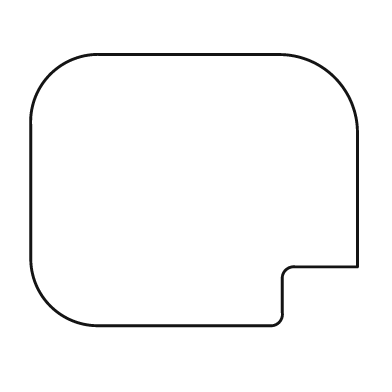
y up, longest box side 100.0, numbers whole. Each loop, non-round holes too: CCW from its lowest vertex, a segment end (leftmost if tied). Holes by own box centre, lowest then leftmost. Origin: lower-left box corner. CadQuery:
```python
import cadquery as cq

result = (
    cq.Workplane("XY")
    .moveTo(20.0, 0.0)
    .lineTo(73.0, 0.0)
    .threePointArc((76.0, 1.0), (77.0, 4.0))
    .lineTo(77.0, 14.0)
    .threePointArc((78.0, 17.0), (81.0, 18.0))
    .lineTo(100.0, 18.0)
    .lineTo(100.0, 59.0)
    .threePointArc((93.0, 76.0), (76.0, 83.0))
    .lineTo(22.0, 83.0)
    .threePointArc((6.0, 77.0), (0.0, 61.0))
    .lineTo(0.0, 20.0)
    .threePointArc((6.0, 6.0), (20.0, 0.0))
    .close()
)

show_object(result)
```